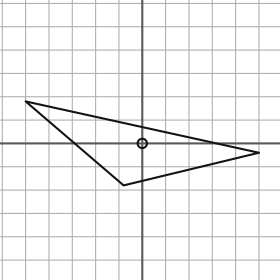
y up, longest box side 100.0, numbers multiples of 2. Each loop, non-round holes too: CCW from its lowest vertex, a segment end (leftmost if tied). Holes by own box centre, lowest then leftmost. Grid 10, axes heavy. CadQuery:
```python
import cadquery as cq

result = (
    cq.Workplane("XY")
    .moveTo(-8.0, -18.0)
    .lineTo(50.0, -4.0)
    .lineTo(-50.0, 18.0)
    .close()
    .moveTo(0.0, 0.0)
    .circle(2.0)
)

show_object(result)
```